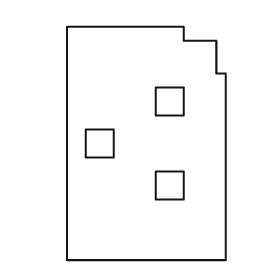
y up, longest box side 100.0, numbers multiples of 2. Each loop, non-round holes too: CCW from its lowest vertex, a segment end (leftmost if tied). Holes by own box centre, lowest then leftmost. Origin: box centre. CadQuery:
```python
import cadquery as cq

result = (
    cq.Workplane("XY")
    .moveTo(-34.0, -50.0)
    .lineTo(34.0, -50.0)
    .lineTo(34.0, 30.0)
    .lineTo(30.0, 30.0)
    .lineTo(30.0, 44.0)
    .lineTo(16.0, 44.0)
    .lineTo(16.0, 50.0)
    .lineTo(-34.0, 50.0)
    .close()
    .moveTo(4.0, -24.0)
    .lineTo(16.0, -24.0)
    .lineTo(16.0, -12.0)
    .lineTo(4.0, -12.0)
    .close()
    .moveTo(-26.0, -6.0)
    .lineTo(-14.0, -6.0)
    .lineTo(-14.0, 6.0)
    .lineTo(-26.0, 6.0)
    .close()
    .moveTo(4.0, 12.0)
    .lineTo(16.0, 12.0)
    .lineTo(16.0, 24.0)
    .lineTo(4.0, 24.0)
    .close()
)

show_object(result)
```